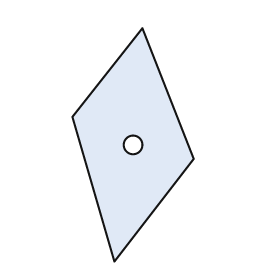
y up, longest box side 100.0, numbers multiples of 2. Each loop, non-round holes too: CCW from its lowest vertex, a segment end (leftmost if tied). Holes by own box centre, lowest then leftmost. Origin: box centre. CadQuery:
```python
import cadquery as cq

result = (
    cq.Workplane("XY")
    .moveTo(-8.0, -50.0)
    .lineTo(26.0, -6.0)
    .lineTo(4.0, 50.0)
    .lineTo(-26.0, 12.0)
    .close()
    .moveTo(0.0, 0.0)
    .circle(4.0)
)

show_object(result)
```